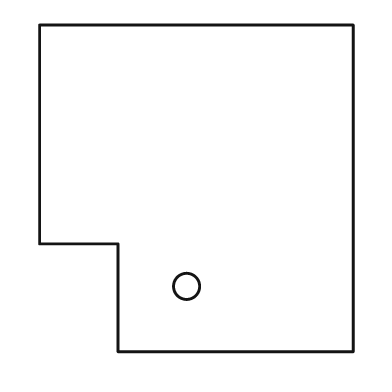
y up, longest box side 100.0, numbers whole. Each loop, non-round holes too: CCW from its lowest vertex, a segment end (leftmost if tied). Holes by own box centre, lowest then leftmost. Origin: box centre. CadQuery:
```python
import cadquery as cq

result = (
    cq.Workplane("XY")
    .moveTo(-24.0, -50.0)
    .lineTo(48.0, -50.0)
    .lineTo(48.0, 50.0)
    .lineTo(-48.0, 50.0)
    .lineTo(-48.0, -17.0)
    .lineTo(-24.0, -17.0)
    .close()
    .moveTo(-3.0, -30.0)
    .circle(4.0)
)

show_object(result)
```